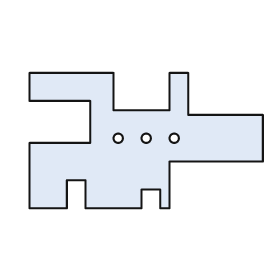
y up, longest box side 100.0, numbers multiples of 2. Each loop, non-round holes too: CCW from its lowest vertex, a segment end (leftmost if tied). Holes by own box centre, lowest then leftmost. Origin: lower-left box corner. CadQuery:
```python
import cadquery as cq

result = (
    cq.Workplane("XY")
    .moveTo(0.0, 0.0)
    .lineTo(16.0, 0.0)
    .lineTo(16.0, 12.0)
    .lineTo(24.0, 12.0)
    .lineTo(24.0, 0.0)
    .lineTo(48.0, 0.0)
    .lineTo(48.0, 8.0)
    .lineTo(56.0, 8.0)
    .lineTo(56.0, 0.0)
    .lineTo(60.0, 0.0)
    .lineTo(60.0, 20.0)
    .lineTo(100.0, 20.0)
    .lineTo(100.0, 40.0)
    .lineTo(68.0, 40.0)
    .lineTo(68.0, 58.0)
    .lineTo(60.0, 58.0)
    .lineTo(60.0, 42.0)
    .lineTo(36.0, 42.0)
    .lineTo(36.0, 58.0)
    .lineTo(0.0, 58.0)
    .lineTo(0.0, 46.0)
    .lineTo(26.0, 46.0)
    .lineTo(26.0, 28.0)
    .lineTo(0.0, 28.0)
    .close()
    .moveTo(38.0, 30.0)
    .circle(2.0)
    .moveTo(50.0, 30.0)
    .circle(2.0)
    .moveTo(62.0, 30.0)
    .circle(2.0)
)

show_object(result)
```